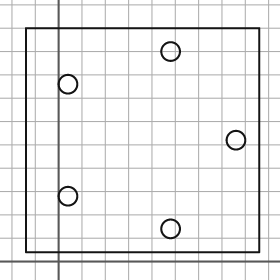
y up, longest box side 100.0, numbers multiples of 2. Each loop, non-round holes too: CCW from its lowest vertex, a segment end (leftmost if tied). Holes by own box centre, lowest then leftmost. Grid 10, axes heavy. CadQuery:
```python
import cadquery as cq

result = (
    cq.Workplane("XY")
    .moveTo(-14.0, 4.0)
    .lineTo(86.0, 4.0)
    .lineTo(86.0, 100.0)
    .lineTo(-14.0, 100.0)
    .close()
    .moveTo(48.0, 14.0)
    .circle(4.0)
    .moveTo(4.0, 28.0)
    .circle(4.0)
    .moveTo(76.0, 52.0)
    .circle(4.0)
    .moveTo(4.0, 76.0)
    .circle(4.0)
    .moveTo(48.0, 90.0)
    .circle(4.0)
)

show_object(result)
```